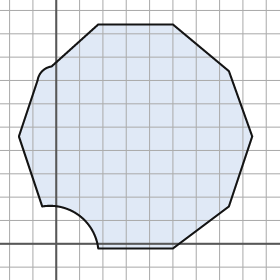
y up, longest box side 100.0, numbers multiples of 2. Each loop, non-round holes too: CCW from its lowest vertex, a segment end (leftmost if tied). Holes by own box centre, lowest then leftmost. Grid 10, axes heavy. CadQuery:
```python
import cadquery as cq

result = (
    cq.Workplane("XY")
    .moveTo(18.0, -2.0)
    .lineTo(50.0, -2.0)
    .lineTo(74.0, 16.0)
    .lineTo(84.0, 46.0)
    .lineTo(74.0, 74.0)
    .lineTo(50.0, 94.0)
    .lineTo(18.0, 94.0)
    .lineTo(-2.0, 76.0)
    .threePointArc((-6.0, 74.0), (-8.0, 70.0))
    .lineTo(-16.0, 46.0)
    .lineTo(-6.0, 16.0)
    .threePointArc((10.0, 12.0), (18.0, -2.0))
    .close()
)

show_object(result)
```